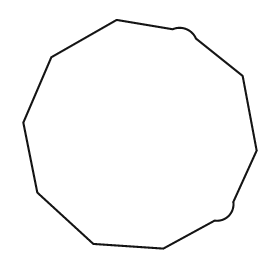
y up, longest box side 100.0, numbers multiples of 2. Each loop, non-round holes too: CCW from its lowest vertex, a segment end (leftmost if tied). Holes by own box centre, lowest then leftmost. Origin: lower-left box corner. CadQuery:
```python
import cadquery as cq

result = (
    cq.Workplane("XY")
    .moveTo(60.0, 0.0)
    .lineTo(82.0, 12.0)
    .threePointArc((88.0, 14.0), (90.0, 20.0))
    .lineTo(100.0, 42.0)
    .lineTo(94.0, 74.0)
    .lineTo(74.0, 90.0)
    .threePointArc((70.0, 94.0), (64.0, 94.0))
    .lineTo(40.0, 98.0)
    .lineTo(12.0, 82.0)
    .lineTo(0.0, 54.0)
    .lineTo(6.0, 24.0)
    .lineTo(30.0, 2.0)
    .close()
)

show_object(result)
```